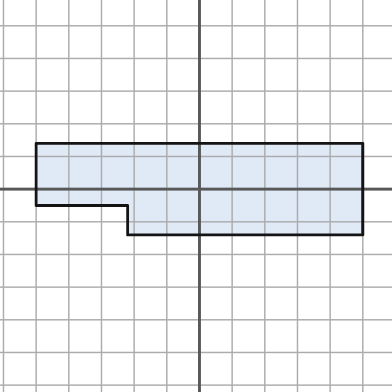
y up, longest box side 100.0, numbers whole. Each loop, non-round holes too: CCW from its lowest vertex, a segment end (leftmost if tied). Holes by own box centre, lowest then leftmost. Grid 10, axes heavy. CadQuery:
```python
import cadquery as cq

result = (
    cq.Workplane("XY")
    .moveTo(-22.0, -14.0)
    .lineTo(50.0, -14.0)
    .lineTo(50.0, 14.0)
    .lineTo(-50.0, 14.0)
    .lineTo(-50.0, -5.0)
    .lineTo(-22.0, -5.0)
    .close()
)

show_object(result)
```